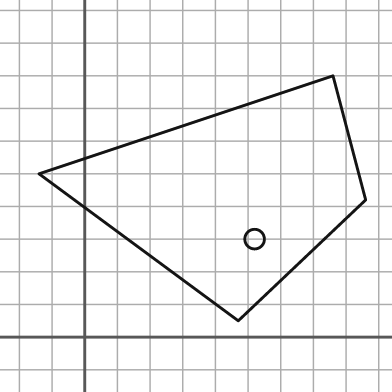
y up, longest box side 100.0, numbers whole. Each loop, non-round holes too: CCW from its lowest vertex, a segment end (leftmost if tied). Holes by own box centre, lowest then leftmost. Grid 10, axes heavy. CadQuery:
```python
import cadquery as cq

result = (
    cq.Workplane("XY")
    .moveTo(47.0, 5.0)
    .lineTo(86.0, 42.0)
    .lineTo(76.0, 80.0)
    .lineTo(-14.0, 50.0)
    .close()
    .moveTo(52.0, 30.0)
    .circle(3.0)
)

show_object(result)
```